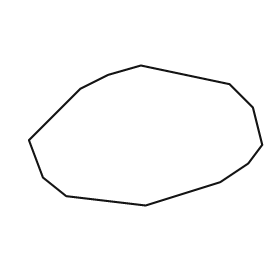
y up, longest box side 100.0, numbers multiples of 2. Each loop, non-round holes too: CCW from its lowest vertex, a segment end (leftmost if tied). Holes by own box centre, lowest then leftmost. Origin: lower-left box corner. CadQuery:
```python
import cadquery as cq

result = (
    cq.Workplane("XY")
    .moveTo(50.0, 0.0)
    .lineTo(82.0, 10.0)
    .lineTo(94.0, 18.0)
    .lineTo(100.0, 26.0)
    .lineTo(96.0, 42.0)
    .lineTo(86.0, 52.0)
    .lineTo(48.0, 60.0)
    .lineTo(34.0, 56.0)
    .lineTo(22.0, 50.0)
    .lineTo(0.0, 28.0)
    .lineTo(6.0, 12.0)
    .lineTo(16.0, 4.0)
    .close()
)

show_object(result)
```